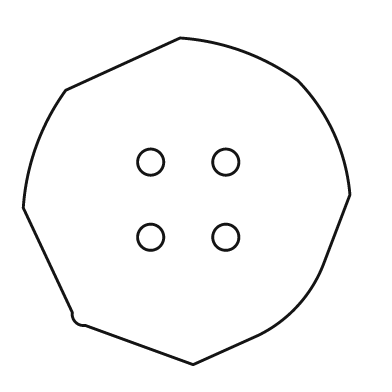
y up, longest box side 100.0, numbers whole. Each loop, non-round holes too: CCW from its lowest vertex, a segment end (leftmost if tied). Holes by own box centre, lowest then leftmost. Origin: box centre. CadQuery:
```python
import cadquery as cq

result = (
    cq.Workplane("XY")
    .moveTo(2.0, -50.0)
    .lineTo(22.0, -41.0)
    .threePointArc((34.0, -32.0), (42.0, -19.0))
    .lineTo(50.0, 2.0)
    .threePointArc((45.0, 21.0), (34.0, 37.0))
    .threePointArc((17.0, 46.0), (-2.0, 50.0))
    .lineTo(-37.0, 34.0)
    .threePointArc((-46.0, 17.0), (-50.0, -2.0))
    .lineTo(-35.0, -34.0)
    .threePointArc((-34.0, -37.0), (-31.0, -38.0))
    .close()
    .moveTo(-11.0, -11.0)
    .circle(4.0)
    .moveTo(12.0, -11.0)
    .circle(4.0)
    .moveTo(-11.0, 12.0)
    .circle(4.0)
    .moveTo(12.0, 12.0)
    .circle(4.0)
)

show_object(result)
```